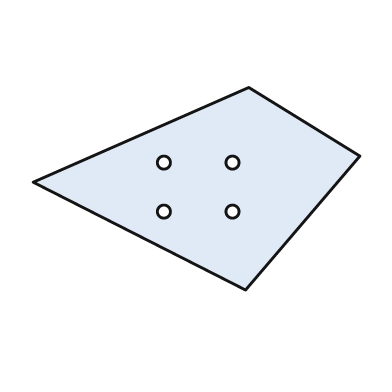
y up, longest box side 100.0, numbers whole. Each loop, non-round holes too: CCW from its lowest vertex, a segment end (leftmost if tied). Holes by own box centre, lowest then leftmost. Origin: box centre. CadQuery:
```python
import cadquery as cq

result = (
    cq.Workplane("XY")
    .moveTo(15.0, -31.0)
    .lineTo(50.0, 10.0)
    .lineTo(16.0, 31.0)
    .lineTo(-50.0, 2.0)
    .close()
    .moveTo(-10.0, -7.0)
    .circle(2.0)
    .moveTo(11.0, -7.0)
    .circle(2.0)
    .moveTo(-10.0, 8.0)
    .circle(2.0)
    .moveTo(11.0, 8.0)
    .circle(2.0)
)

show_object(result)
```